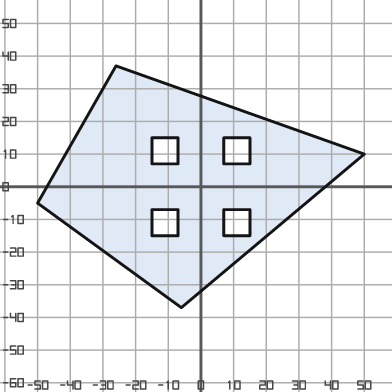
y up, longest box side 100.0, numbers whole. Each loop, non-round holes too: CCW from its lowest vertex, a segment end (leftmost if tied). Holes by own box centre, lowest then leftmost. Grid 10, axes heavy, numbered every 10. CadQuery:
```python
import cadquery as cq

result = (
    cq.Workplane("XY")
    .moveTo(-6.0, -37.0)
    .lineTo(50.0, 10.0)
    .lineTo(-26.0, 37.0)
    .lineTo(-50.0, -5.0)
    .close()
    .moveTo(-15.0, -15.0)
    .lineTo(-7.0, -15.0)
    .lineTo(-7.0, -7.0)
    .lineTo(-15.0, -7.0)
    .close()
    .moveTo(7.0, -15.0)
    .lineTo(15.0, -15.0)
    .lineTo(15.0, -7.0)
    .lineTo(7.0, -7.0)
    .close()
    .moveTo(-15.0, 7.0)
    .lineTo(-7.0, 7.0)
    .lineTo(-7.0, 15.0)
    .lineTo(-15.0, 15.0)
    .close()
    .moveTo(7.0, 7.0)
    .lineTo(15.0, 7.0)
    .lineTo(15.0, 15.0)
    .lineTo(7.0, 15.0)
    .close()
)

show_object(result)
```